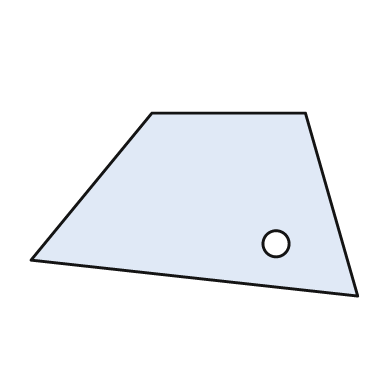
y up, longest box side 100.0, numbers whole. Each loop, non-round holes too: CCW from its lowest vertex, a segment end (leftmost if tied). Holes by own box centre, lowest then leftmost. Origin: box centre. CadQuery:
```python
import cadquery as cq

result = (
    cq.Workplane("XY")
    .moveTo(50.0, -28.0)
    .lineTo(34.0, 28.0)
    .lineTo(-13.0, 28.0)
    .lineTo(-50.0, -17.0)
    .close()
    .moveTo(25.0, -12.0)
    .circle(4.0)
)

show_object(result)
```